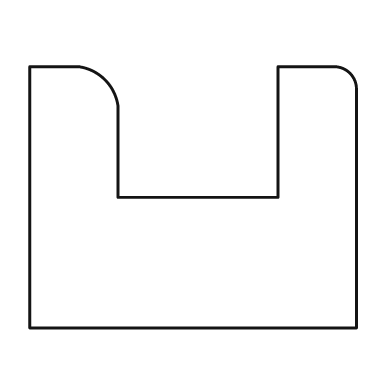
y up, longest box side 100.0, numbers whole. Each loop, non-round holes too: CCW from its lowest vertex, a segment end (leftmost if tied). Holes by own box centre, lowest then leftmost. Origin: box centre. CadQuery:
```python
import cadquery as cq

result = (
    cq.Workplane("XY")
    .moveTo(-50.0, -40.0)
    .lineTo(50.0, -40.0)
    .lineTo(50.0, 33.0)
    .threePointArc((48.0, 38.0), (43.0, 40.0))
    .lineTo(26.0, 40.0)
    .lineTo(26.0, 0.0)
    .lineTo(-23.0, 0.0)
    .lineTo(-23.0, 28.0)
    .threePointArc((-27.0, 36.0), (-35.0, 40.0))
    .lineTo(-50.0, 40.0)
    .close()
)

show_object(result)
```